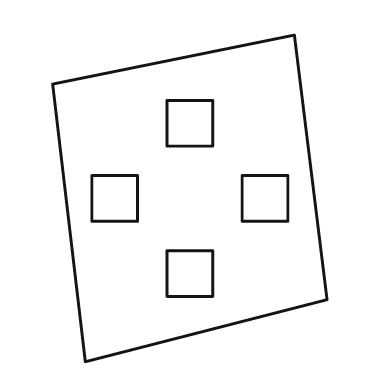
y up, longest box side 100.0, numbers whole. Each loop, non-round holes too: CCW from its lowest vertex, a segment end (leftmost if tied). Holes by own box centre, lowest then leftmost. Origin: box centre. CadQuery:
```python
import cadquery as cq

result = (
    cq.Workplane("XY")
    .moveTo(-32.0, -50.0)
    .lineTo(42.0, -31.0)
    .lineTo(32.0, 50.0)
    .lineTo(-42.0, 35.0)
    .close()
    .moveTo(-7.0, -30.0)
    .lineTo(7.0, -30.0)
    .lineTo(7.0, -16.0)
    .lineTo(-7.0, -16.0)
    .close()
    .moveTo(-30.0, -7.0)
    .lineTo(-16.0, -7.0)
    .lineTo(-16.0, 7.0)
    .lineTo(-30.0, 7.0)
    .close()
    .moveTo(16.0, -7.0)
    .lineTo(30.0, -7.0)
    .lineTo(30.0, 7.0)
    .lineTo(16.0, 7.0)
    .close()
    .moveTo(-7.0, 16.0)
    .lineTo(7.0, 16.0)
    .lineTo(7.0, 30.0)
    .lineTo(-7.0, 30.0)
    .close()
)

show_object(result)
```